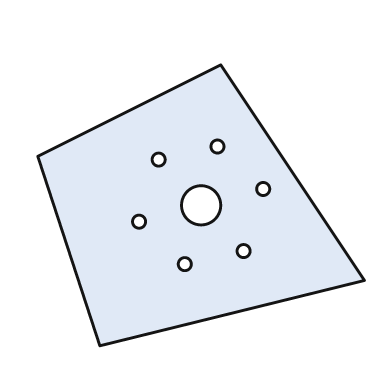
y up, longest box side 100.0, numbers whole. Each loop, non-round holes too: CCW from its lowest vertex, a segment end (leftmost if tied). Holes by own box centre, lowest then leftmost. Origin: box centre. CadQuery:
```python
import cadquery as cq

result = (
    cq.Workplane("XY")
    .moveTo(-31.0, -43.0)
    .lineTo(50.0, -23.0)
    .lineTo(6.0, 43.0)
    .lineTo(-50.0, 15.0)
    .close()
    .moveTo(-5.0, -18.0)
    .circle(2.0)
    .moveTo(13.0, -14.0)
    .circle(2.0)
    .moveTo(-19.0, -5.0)
    .circle(2.0)
    .moveTo(0.0, 0.0)
    .circle(6.0)
    .moveTo(19.0, 5.0)
    .circle(2.0)
    .moveTo(-13.0, 14.0)
    .circle(2.0)
    .moveTo(5.0, 18.0)
    .circle(2.0)
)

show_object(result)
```